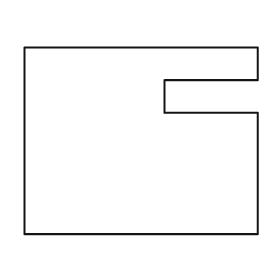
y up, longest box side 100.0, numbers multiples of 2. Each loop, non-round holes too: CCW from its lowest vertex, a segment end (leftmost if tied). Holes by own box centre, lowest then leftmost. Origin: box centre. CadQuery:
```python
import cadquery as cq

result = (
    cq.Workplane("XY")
    .moveTo(-50.0, -40.0)
    .lineTo(50.0, -40.0)
    .lineTo(50.0, 12.0)
    .lineTo(10.0, 12.0)
    .lineTo(10.0, 26.0)
    .lineTo(50.0, 26.0)
    .lineTo(50.0, 40.0)
    .lineTo(-50.0, 40.0)
    .close()
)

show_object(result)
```